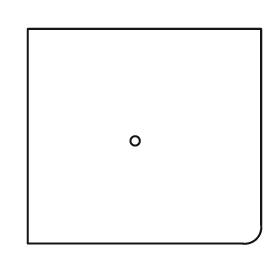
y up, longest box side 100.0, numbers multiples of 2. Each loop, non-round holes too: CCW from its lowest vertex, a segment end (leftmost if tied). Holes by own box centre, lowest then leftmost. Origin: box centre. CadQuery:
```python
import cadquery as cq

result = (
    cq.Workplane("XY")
    .moveTo(-50.0, -46.0)
    .lineTo(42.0, -46.0)
    .threePointArc((48.0, -44.0), (50.0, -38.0))
    .lineTo(50.0, 46.0)
    .lineTo(-50.0, 46.0)
    .close()
    .moveTo(-4.0, -2.0)
    .circle(2.0)
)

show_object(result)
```